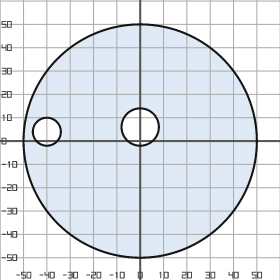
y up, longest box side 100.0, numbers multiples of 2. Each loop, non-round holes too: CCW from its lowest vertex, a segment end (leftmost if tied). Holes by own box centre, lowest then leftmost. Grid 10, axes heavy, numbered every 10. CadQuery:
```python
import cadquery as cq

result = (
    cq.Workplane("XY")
    .moveTo(0.0, 0.0)
    .circle(50.0)
    .moveTo(-40.0, 4.0)
    .circle(6.0)
    .moveTo(0.0, 6.0)
    .circle(8.0)
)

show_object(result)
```